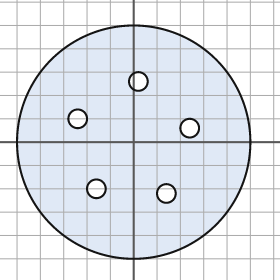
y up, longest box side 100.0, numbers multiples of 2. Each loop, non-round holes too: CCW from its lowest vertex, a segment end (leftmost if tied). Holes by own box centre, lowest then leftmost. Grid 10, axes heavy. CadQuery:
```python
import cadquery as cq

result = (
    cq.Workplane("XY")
    .moveTo(0.0, 0.0)
    .circle(50.0)
    .moveTo(14.0, -22.0)
    .circle(4.0)
    .moveTo(-16.0, -20.0)
    .circle(4.0)
    .moveTo(24.0, 6.0)
    .circle(4.0)
    .moveTo(-24.0, 10.0)
    .circle(4.0)
    .moveTo(2.0, 26.0)
    .circle(4.0)
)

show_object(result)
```